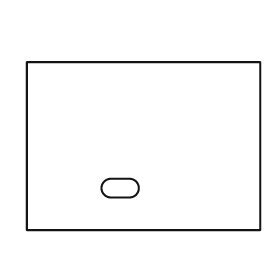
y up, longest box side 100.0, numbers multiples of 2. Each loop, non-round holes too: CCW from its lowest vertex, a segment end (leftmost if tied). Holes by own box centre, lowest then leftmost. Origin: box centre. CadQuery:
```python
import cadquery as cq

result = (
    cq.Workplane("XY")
    .moveTo(-50.0, -36.0)
    .lineTo(50.0, -36.0)
    .lineTo(50.0, 36.0)
    .lineTo(-50.0, 36.0)
    .close()
    .moveTo(-14.0, -22.0)
    .lineTo(-6.0, -22.0)
    .threePointArc((-2.0, -18.0), (-6.0, -14.0))
    .lineTo(-14.0, -14.0)
    .threePointArc((-18.0, -18.0), (-14.0, -22.0))
    .close()
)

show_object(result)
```